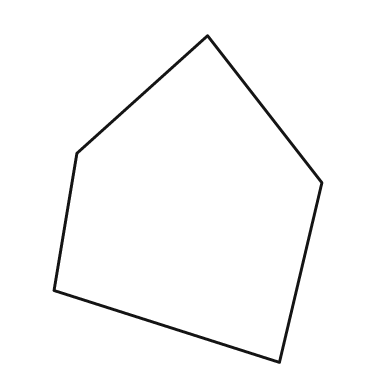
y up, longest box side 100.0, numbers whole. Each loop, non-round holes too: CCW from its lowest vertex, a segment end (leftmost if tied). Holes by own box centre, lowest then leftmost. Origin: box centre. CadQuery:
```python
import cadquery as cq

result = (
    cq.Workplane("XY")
    .moveTo(28.0, -50.0)
    .lineTo(41.0, 5.0)
    .lineTo(6.0, 50.0)
    .lineTo(-34.0, 14.0)
    .lineTo(-41.0, -28.0)
    .close()
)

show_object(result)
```